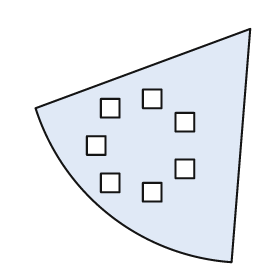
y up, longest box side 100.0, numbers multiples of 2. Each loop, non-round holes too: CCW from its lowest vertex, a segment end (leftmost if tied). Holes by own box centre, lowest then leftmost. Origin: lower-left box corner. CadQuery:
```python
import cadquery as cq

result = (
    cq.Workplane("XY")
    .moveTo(84.0, 0.0)
    .lineTo(92.0, 100.0)
    .lineTo(0.0, 66.0)
    .threePointArc((32.0, 20.0), (84.0, 0.0))
    .close()
    .moveTo(46.0, 26.0)
    .lineTo(54.0, 26.0)
    .lineTo(54.0, 34.0)
    .lineTo(46.0, 34.0)
    .close()
    .moveTo(28.0, 30.0)
    .lineTo(36.0, 30.0)
    .lineTo(36.0, 38.0)
    .lineTo(28.0, 38.0)
    .close()
    .moveTo(60.0, 36.0)
    .lineTo(68.0, 36.0)
    .lineTo(68.0, 44.0)
    .lineTo(60.0, 44.0)
    .close()
    .moveTo(22.0, 46.0)
    .lineTo(30.0, 46.0)
    .lineTo(30.0, 54.0)
    .lineTo(22.0, 54.0)
    .close()
    .moveTo(60.0, 56.0)
    .lineTo(68.0, 56.0)
    .lineTo(68.0, 64.0)
    .lineTo(60.0, 64.0)
    .close()
    .moveTo(28.0, 62.0)
    .lineTo(36.0, 62.0)
    .lineTo(36.0, 70.0)
    .lineTo(28.0, 70.0)
    .close()
    .moveTo(46.0, 66.0)
    .lineTo(54.0, 66.0)
    .lineTo(54.0, 74.0)
    .lineTo(46.0, 74.0)
    .close()
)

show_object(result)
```